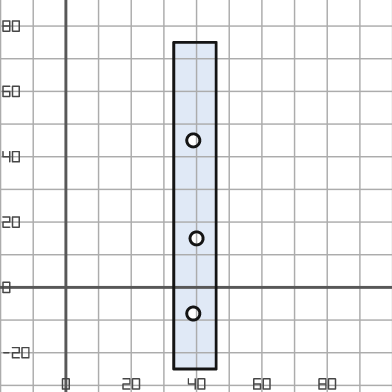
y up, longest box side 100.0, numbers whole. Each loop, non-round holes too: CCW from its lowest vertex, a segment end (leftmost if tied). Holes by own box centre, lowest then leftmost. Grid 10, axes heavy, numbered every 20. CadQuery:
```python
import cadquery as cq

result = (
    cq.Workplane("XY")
    .moveTo(33.0, -25.0)
    .lineTo(46.0, -25.0)
    .lineTo(46.0, 75.0)
    .lineTo(33.0, 75.0)
    .close()
    .moveTo(39.0, -8.0)
    .circle(2.0)
    .moveTo(40.0, 15.0)
    .circle(2.0)
    .moveTo(39.0, 45.0)
    .circle(2.0)
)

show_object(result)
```